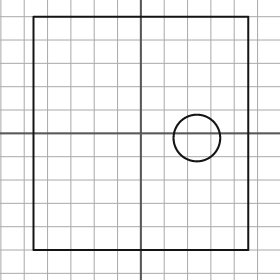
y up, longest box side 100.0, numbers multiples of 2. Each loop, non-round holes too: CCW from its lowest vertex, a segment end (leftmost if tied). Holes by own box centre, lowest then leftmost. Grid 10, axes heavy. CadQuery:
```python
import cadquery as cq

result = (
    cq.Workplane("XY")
    .moveTo(-46.0, -50.0)
    .lineTo(46.0, -50.0)
    .lineTo(46.0, 50.0)
    .lineTo(-46.0, 50.0)
    .close()
    .moveTo(24.0, -2.0)
    .circle(10.0)
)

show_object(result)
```